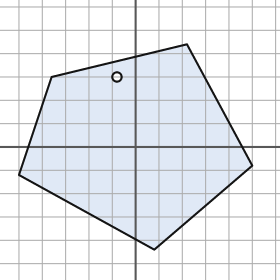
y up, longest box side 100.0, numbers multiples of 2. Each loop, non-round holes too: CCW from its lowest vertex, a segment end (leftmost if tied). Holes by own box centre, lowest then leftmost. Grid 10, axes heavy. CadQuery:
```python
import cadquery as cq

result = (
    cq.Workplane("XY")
    .moveTo(8.0, -44.0)
    .lineTo(50.0, -8.0)
    .lineTo(22.0, 44.0)
    .lineTo(-36.0, 30.0)
    .lineTo(-50.0, -12.0)
    .close()
    .moveTo(-8.0, 30.0)
    .circle(2.0)
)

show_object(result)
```